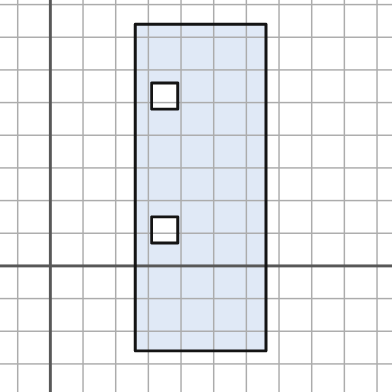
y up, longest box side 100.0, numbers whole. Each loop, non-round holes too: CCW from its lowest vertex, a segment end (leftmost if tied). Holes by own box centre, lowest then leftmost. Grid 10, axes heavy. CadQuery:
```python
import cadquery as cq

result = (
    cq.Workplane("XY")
    .moveTo(26.0, -26.0)
    .lineTo(66.0, -26.0)
    .lineTo(66.0, 74.0)
    .lineTo(26.0, 74.0)
    .close()
    .moveTo(31.0, 7.0)
    .lineTo(39.0, 7.0)
    .lineTo(39.0, 15.0)
    .lineTo(31.0, 15.0)
    .close()
    .moveTo(31.0, 48.0)
    .lineTo(39.0, 48.0)
    .lineTo(39.0, 56.0)
    .lineTo(31.0, 56.0)
    .close()
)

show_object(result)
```